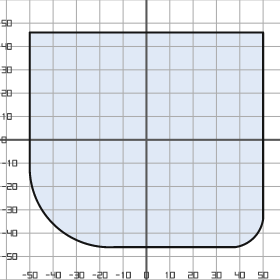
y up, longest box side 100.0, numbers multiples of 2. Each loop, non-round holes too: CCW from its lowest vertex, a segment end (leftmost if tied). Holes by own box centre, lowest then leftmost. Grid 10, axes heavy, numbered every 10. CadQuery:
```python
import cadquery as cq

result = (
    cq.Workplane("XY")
    .moveTo(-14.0, -46.0)
    .lineTo(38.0, -46.0)
    .threePointArc((46.0, -42.0), (50.0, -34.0))
    .lineTo(50.0, 46.0)
    .lineTo(-50.0, 46.0)
    .lineTo(-50.0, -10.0)
    .threePointArc((-40.0, -36.0), (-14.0, -46.0))
    .close()
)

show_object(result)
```